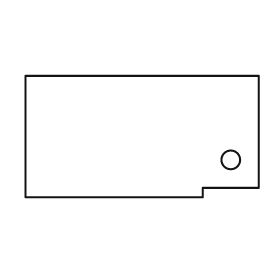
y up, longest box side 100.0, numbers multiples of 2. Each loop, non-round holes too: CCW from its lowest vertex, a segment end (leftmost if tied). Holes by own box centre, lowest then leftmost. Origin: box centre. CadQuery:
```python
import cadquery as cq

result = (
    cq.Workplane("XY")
    .moveTo(-50.0, -26.0)
    .lineTo(26.0, -26.0)
    .lineTo(26.0, -22.0)
    .lineTo(50.0, -22.0)
    .lineTo(50.0, 26.0)
    .lineTo(-50.0, 26.0)
    .close()
    .moveTo(38.0, -10.0)
    .circle(4.0)
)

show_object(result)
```